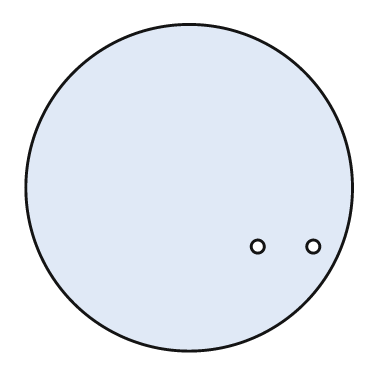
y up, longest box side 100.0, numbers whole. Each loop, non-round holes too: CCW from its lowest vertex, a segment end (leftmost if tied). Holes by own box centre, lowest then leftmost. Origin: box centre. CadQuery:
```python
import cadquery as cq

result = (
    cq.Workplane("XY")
    .moveTo(0.0, 0.0)
    .circle(50.0)
    .moveTo(21.0, -18.0)
    .circle(2.0)
    .moveTo(38.0, -18.0)
    .circle(2.0)
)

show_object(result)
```